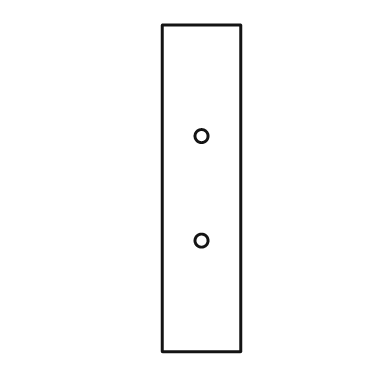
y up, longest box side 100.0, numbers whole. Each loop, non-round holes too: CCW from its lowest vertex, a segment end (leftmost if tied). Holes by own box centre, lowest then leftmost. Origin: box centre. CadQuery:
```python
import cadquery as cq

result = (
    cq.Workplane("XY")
    .moveTo(-12.0, -50.0)
    .lineTo(12.0, -50.0)
    .lineTo(12.0, 50.0)
    .lineTo(-12.0, 50.0)
    .close()
    .moveTo(0.0, -16.0)
    .circle(2.0)
    .moveTo(0.0, 16.0)
    .circle(2.0)
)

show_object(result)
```